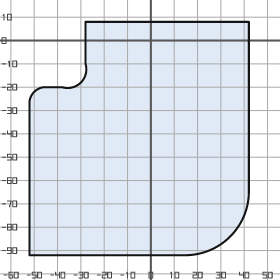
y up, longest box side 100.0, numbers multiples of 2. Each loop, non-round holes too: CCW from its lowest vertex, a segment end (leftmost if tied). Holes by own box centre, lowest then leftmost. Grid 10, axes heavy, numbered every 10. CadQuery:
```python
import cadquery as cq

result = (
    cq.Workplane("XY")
    .moveTo(-52.0, -92.0)
    .lineTo(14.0, -92.0)
    .threePointArc((34.0, -84.0), (42.0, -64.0))
    .lineTo(42.0, 8.0)
    .lineTo(-28.0, 8.0)
    .lineTo(-28.0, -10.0)
    .threePointArc((-30.0, -18.0), (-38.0, -20.0))
    .lineTo(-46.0, -20.0)
    .threePointArc((-50.0, -22.0), (-52.0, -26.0))
    .close()
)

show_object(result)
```